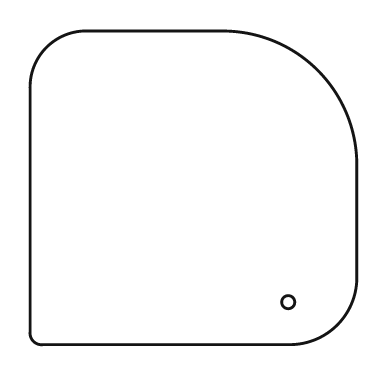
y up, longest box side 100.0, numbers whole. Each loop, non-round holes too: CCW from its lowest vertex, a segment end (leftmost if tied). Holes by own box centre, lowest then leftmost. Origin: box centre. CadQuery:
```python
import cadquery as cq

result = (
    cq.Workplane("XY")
    .moveTo(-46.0, -48.0)
    .lineTo(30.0, -48.0)
    .threePointArc((44.0, -42.0), (50.0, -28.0))
    .lineTo(50.0, 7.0)
    .threePointArc((38.0, 36.0), (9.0, 48.0))
    .lineTo(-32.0, 48.0)
    .threePointArc((-45.0, 43.0), (-50.0, 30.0))
    .lineTo(-50.0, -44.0)
    .threePointArc((-49.0, -47.0), (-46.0, -48.0))
    .close()
    .moveTo(29.0, -35.0)
    .circle(2.0)
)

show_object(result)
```